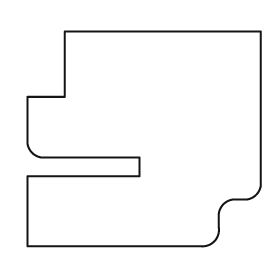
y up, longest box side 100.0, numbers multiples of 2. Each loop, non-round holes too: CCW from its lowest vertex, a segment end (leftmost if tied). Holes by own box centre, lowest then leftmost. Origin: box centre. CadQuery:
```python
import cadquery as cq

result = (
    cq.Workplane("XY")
    .moveTo(-50.0, -46.0)
    .lineTo(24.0, -46.0)
    .threePointArc((30.0, -44.0), (32.0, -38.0))
    .lineTo(32.0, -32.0)
    .threePointArc((34.0, -28.0), (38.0, -26.0))
    .lineTo(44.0, -26.0)
    .threePointArc((48.0, -24.0), (50.0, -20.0))
    .lineTo(50.0, 46.0)
    .lineTo(-34.0, 46.0)
    .lineTo(-34.0, 18.0)
    .lineTo(-50.0, 18.0)
    .lineTo(-50.0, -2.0)
    .threePointArc((-48.0, -6.0), (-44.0, -8.0))
    .lineTo(-2.0, -8.0)
    .lineTo(-2.0, -16.0)
    .lineTo(-50.0, -16.0)
    .close()
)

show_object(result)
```